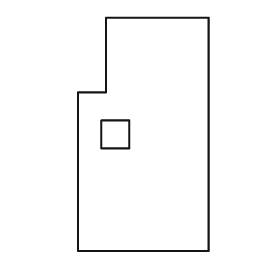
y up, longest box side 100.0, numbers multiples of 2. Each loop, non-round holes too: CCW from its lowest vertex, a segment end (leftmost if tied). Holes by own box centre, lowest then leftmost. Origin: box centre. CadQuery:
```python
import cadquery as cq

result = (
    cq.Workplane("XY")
    .moveTo(-28.0, -50.0)
    .lineTo(28.0, -50.0)
    .lineTo(28.0, 50.0)
    .lineTo(-16.0, 50.0)
    .lineTo(-16.0, 18.0)
    .lineTo(-28.0, 18.0)
    .close()
    .moveTo(-18.0, -6.0)
    .lineTo(-6.0, -6.0)
    .lineTo(-6.0, 6.0)
    .lineTo(-18.0, 6.0)
    .close()
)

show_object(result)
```